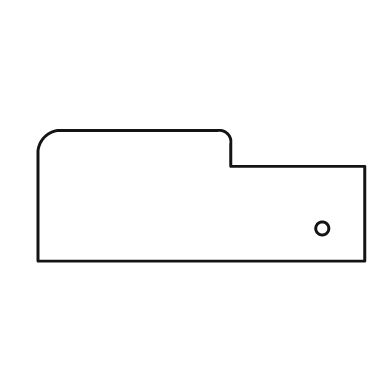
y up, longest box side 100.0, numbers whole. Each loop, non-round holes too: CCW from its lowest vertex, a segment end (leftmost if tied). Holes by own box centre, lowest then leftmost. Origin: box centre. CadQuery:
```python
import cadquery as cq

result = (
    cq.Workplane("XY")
    .moveTo(-50.0, -20.0)
    .lineTo(50.0, -20.0)
    .lineTo(50.0, 9.0)
    .lineTo(9.0, 9.0)
    .lineTo(9.0, 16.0)
    .threePointArc((8.0, 19.0), (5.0, 20.0))
    .lineTo(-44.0, 20.0)
    .threePointArc((-48.0, 18.0), (-50.0, 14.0))
    .close()
    .moveTo(37.0, -10.0)
    .circle(2.0)
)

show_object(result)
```